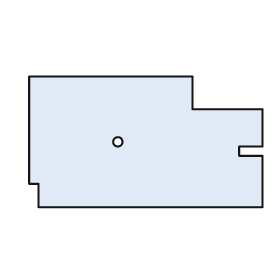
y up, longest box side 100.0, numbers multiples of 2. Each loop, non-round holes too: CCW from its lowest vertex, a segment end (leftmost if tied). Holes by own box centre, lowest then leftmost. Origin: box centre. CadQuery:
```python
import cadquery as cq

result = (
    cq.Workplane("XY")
    .moveTo(-46.0, -28.0)
    .lineTo(50.0, -28.0)
    .lineTo(50.0, -6.0)
    .lineTo(40.0, -6.0)
    .lineTo(40.0, -2.0)
    .lineTo(50.0, -2.0)
    .lineTo(50.0, 14.0)
    .lineTo(20.0, 14.0)
    .lineTo(20.0, 28.0)
    .lineTo(-50.0, 28.0)
    .lineTo(-50.0, -18.0)
    .lineTo(-46.0, -18.0)
    .close()
    .moveTo(-12.0, 0.0)
    .circle(2.0)
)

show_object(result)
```